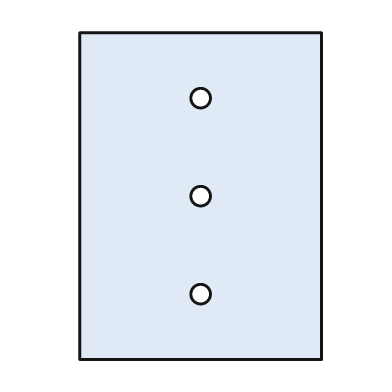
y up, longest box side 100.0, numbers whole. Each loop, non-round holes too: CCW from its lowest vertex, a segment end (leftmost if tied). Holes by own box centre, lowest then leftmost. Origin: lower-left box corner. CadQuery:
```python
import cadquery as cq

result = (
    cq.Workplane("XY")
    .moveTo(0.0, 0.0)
    .lineTo(74.0, 0.0)
    .lineTo(74.0, 100.0)
    .lineTo(0.0, 100.0)
    .close()
    .moveTo(37.0, 20.0)
    .circle(3.0)
    .moveTo(37.0, 50.0)
    .circle(3.0)
    .moveTo(37.0, 80.0)
    .circle(3.0)
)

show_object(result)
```